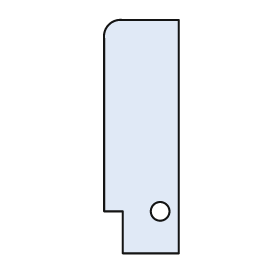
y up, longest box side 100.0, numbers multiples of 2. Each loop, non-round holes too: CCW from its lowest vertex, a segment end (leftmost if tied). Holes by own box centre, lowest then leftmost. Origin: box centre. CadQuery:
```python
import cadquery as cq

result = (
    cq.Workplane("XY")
    .moveTo(-8.0, -50.0)
    .lineTo(16.0, -50.0)
    .lineTo(16.0, 50.0)
    .lineTo(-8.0, 50.0)
    .threePointArc((-14.0, 48.0), (-16.0, 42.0))
    .lineTo(-16.0, -32.0)
    .lineTo(-8.0, -32.0)
    .close()
    .moveTo(8.0, -32.0)
    .circle(4.0)
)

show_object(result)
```